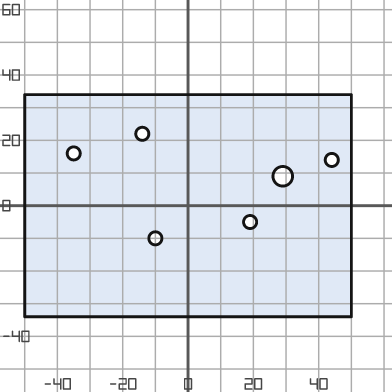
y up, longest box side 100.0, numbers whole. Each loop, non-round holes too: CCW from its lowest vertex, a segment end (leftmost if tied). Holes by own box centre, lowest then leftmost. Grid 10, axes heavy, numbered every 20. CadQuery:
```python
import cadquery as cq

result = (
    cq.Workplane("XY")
    .moveTo(-50.0, -34.0)
    .lineTo(50.0, -34.0)
    .lineTo(50.0, 34.0)
    .lineTo(-50.0, 34.0)
    .close()
    .moveTo(-10.0, -10.0)
    .circle(2.0)
    .moveTo(19.0, -5.0)
    .circle(2.0)
    .moveTo(29.0, 9.0)
    .circle(3.0)
    .moveTo(44.0, 14.0)
    .circle(2.0)
    .moveTo(-35.0, 16.0)
    .circle(2.0)
    .moveTo(-14.0, 22.0)
    .circle(2.0)
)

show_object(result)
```